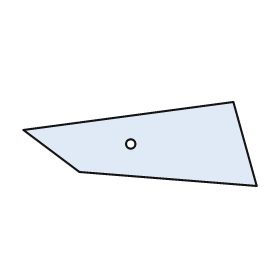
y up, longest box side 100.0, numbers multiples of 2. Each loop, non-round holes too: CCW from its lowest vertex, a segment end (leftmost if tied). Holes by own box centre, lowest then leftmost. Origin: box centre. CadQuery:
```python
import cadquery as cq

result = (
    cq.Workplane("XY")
    .moveTo(50.0, -18.0)
    .lineTo(40.0, 18.0)
    .lineTo(-50.0, 6.0)
    .lineTo(-26.0, -12.0)
    .close()
    .moveTo(-4.0, 0.0)
    .circle(2.0)
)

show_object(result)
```